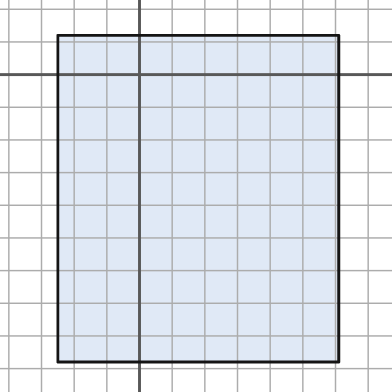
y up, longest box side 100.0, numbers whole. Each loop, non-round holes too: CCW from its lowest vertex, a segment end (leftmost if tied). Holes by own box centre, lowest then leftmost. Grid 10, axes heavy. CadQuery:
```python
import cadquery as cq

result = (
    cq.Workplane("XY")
    .moveTo(-25.0, -88.0)
    .lineTo(61.0, -88.0)
    .lineTo(61.0, 12.0)
    .lineTo(-25.0, 12.0)
    .close()
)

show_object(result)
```